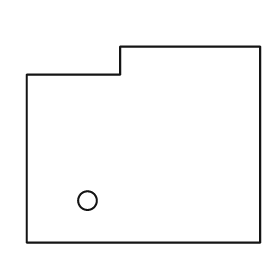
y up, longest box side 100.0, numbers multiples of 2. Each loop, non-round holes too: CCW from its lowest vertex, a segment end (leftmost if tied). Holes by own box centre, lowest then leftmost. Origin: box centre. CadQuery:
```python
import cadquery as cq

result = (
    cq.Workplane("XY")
    .moveTo(-50.0, -42.0)
    .lineTo(50.0, -42.0)
    .lineTo(50.0, 42.0)
    .lineTo(-10.0, 42.0)
    .lineTo(-10.0, 30.0)
    .lineTo(-50.0, 30.0)
    .close()
    .moveTo(-24.0, -24.0)
    .circle(4.0)
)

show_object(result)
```